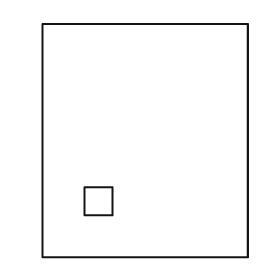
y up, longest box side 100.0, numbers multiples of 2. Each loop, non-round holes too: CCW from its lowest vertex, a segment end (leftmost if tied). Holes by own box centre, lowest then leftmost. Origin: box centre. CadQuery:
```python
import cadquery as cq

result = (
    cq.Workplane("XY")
    .moveTo(-44.0, -50.0)
    .lineTo(44.0, -50.0)
    .lineTo(44.0, 50.0)
    .lineTo(-44.0, 50.0)
    .close()
    .moveTo(-26.0, -32.0)
    .lineTo(-14.0, -32.0)
    .lineTo(-14.0, -20.0)
    .lineTo(-26.0, -20.0)
    .close()
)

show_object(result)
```